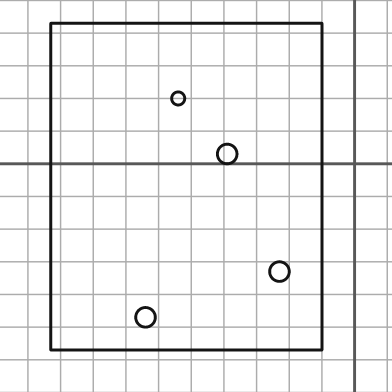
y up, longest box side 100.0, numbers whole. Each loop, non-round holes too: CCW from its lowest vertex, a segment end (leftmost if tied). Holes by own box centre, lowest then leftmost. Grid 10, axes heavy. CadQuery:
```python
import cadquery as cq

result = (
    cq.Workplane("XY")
    .moveTo(-93.0, -57.0)
    .lineTo(-10.0, -57.0)
    .lineTo(-10.0, 43.0)
    .lineTo(-93.0, 43.0)
    .close()
    .moveTo(-64.0, -47.0)
    .circle(3.0)
    .moveTo(-23.0, -33.0)
    .circle(3.0)
    .moveTo(-39.0, 3.0)
    .circle(3.0)
    .moveTo(-54.0, 20.0)
    .circle(2.0)
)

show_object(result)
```